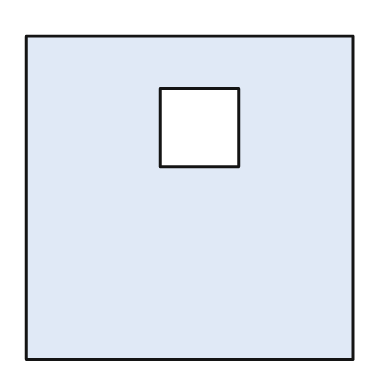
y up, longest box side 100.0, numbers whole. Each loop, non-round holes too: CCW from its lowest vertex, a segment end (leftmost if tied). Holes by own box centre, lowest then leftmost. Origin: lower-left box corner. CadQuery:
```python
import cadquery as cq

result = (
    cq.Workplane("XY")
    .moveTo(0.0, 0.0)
    .lineTo(100.0, 0.0)
    .lineTo(100.0, 99.0)
    .lineTo(0.0, 99.0)
    .close()
    .moveTo(41.0, 59.0)
    .lineTo(65.0, 59.0)
    .lineTo(65.0, 83.0)
    .lineTo(41.0, 83.0)
    .close()
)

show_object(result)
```